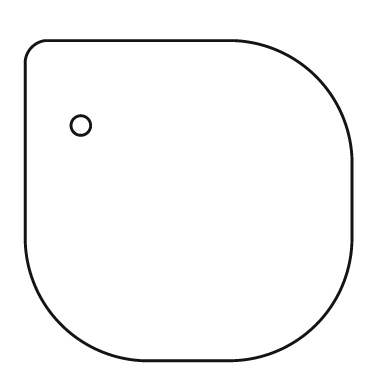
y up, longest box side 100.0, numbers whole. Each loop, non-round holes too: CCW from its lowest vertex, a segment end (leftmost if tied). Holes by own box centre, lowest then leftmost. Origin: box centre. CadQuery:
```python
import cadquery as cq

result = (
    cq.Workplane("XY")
    .moveTo(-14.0, -49.0)
    .lineTo(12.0, -49.0)
    .threePointArc((39.0, -38.0), (50.0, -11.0))
    .lineTo(50.0, 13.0)
    .threePointArc((39.0, 38.0), (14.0, 49.0))
    .lineTo(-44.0, 49.0)
    .threePointArc((-48.0, 47.0), (-50.0, 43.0))
    .lineTo(-50.0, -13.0)
    .threePointArc((-39.0, -38.0), (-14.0, -49.0))
    .close()
    .moveTo(-33.0, 23.0)
    .circle(3.0)
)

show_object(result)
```